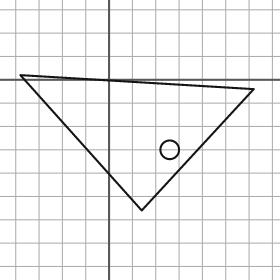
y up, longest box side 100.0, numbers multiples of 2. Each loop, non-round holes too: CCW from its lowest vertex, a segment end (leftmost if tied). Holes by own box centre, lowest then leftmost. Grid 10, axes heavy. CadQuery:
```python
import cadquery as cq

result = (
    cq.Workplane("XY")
    .moveTo(14.0, -56.0)
    .lineTo(62.0, -4.0)
    .lineTo(-38.0, 2.0)
    .close()
    .moveTo(26.0, -30.0)
    .circle(4.0)
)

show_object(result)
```